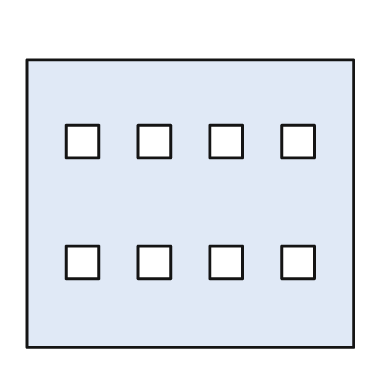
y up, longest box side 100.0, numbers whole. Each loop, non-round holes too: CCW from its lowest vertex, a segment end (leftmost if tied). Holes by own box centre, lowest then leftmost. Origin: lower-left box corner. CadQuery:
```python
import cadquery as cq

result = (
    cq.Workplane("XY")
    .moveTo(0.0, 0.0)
    .lineTo(100.0, 0.0)
    .lineTo(100.0, 88.0)
    .lineTo(0.0, 88.0)
    .close()
    .moveTo(12.0, 21.0)
    .lineTo(22.0, 21.0)
    .lineTo(22.0, 31.0)
    .lineTo(12.0, 31.0)
    .close()
    .moveTo(34.0, 21.0)
    .lineTo(44.0, 21.0)
    .lineTo(44.0, 31.0)
    .lineTo(34.0, 31.0)
    .close()
    .moveTo(56.0, 21.0)
    .lineTo(66.0, 21.0)
    .lineTo(66.0, 31.0)
    .lineTo(56.0, 31.0)
    .close()
    .moveTo(78.0, 21.0)
    .lineTo(88.0, 21.0)
    .lineTo(88.0, 31.0)
    .lineTo(78.0, 31.0)
    .close()
    .moveTo(12.0, 58.0)
    .lineTo(22.0, 58.0)
    .lineTo(22.0, 68.0)
    .lineTo(12.0, 68.0)
    .close()
    .moveTo(34.0, 58.0)
    .lineTo(44.0, 58.0)
    .lineTo(44.0, 68.0)
    .lineTo(34.0, 68.0)
    .close()
    .moveTo(56.0, 58.0)
    .lineTo(66.0, 58.0)
    .lineTo(66.0, 68.0)
    .lineTo(56.0, 68.0)
    .close()
    .moveTo(78.0, 58.0)
    .lineTo(88.0, 58.0)
    .lineTo(88.0, 68.0)
    .lineTo(78.0, 68.0)
    .close()
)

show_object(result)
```